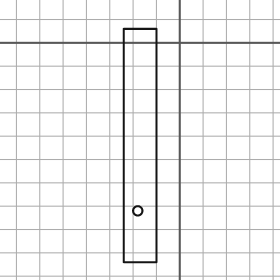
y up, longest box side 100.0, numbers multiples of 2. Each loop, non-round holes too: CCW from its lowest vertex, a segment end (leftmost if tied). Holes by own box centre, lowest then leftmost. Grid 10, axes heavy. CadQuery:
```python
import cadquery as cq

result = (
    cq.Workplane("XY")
    .moveTo(-24.0, -94.0)
    .lineTo(-10.0, -94.0)
    .lineTo(-10.0, 6.0)
    .lineTo(-24.0, 6.0)
    .close()
    .moveTo(-18.0, -72.0)
    .circle(2.0)
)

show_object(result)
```